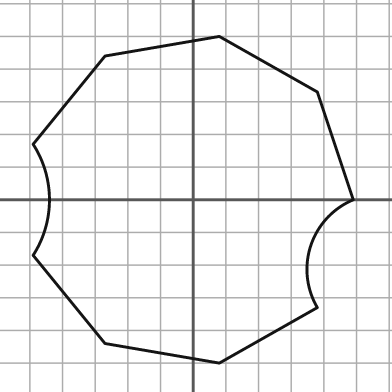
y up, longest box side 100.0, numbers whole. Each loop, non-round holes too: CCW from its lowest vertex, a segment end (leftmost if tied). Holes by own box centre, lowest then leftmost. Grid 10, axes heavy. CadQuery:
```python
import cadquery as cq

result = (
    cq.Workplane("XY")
    .moveTo(8.0, -50.0)
    .lineTo(38.0, -33.0)
    .threePointArc((36.0, -14.0), (49.0, 0.0))
    .lineTo(38.0, 33.0)
    .lineTo(8.0, 50.0)
    .lineTo(-27.0, 44.0)
    .lineTo(-49.0, 17.0)
    .threePointArc((-44.0, 0.0), (-49.0, -17.0))
    .lineTo(-27.0, -44.0)
    .close()
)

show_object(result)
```